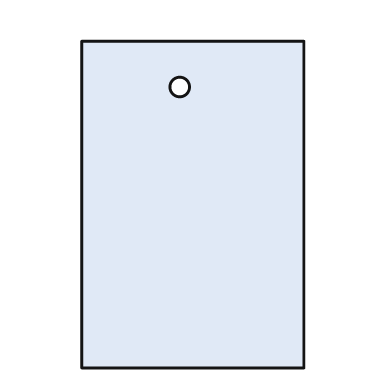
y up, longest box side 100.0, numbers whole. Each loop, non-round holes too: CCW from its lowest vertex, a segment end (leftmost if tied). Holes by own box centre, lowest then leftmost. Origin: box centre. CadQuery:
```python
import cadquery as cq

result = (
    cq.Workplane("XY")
    .moveTo(-34.0, -50.0)
    .lineTo(34.0, -50.0)
    .lineTo(34.0, 50.0)
    .lineTo(-34.0, 50.0)
    .close()
    .moveTo(-4.0, 36.0)
    .circle(3.0)
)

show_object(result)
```